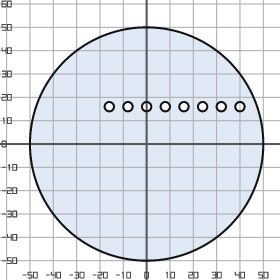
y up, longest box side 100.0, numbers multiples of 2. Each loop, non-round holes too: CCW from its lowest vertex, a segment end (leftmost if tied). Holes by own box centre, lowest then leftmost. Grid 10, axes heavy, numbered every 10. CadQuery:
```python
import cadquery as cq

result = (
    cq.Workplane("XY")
    .moveTo(0.0, 0.0)
    .circle(50.0)
    .moveTo(-16.0, 16.0)
    .circle(2.0)
    .moveTo(-8.0, 16.0)
    .circle(2.0)
    .moveTo(0.0, 16.0)
    .circle(2.0)
    .moveTo(8.0, 16.0)
    .circle(2.0)
    .moveTo(16.0, 16.0)
    .circle(2.0)
    .moveTo(24.0, 16.0)
    .circle(2.0)
    .moveTo(32.0, 16.0)
    .circle(2.0)
    .moveTo(40.0, 16.0)
    .circle(2.0)
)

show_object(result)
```